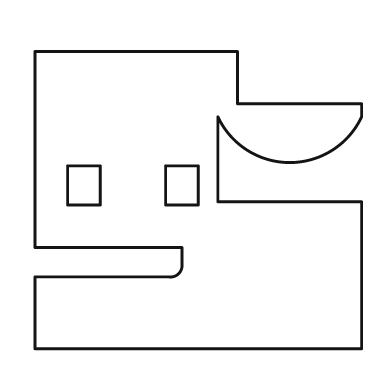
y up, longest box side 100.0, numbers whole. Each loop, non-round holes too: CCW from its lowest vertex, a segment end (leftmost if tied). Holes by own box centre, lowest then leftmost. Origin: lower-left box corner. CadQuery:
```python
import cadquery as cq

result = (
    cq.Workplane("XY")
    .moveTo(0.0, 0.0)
    .lineTo(100.0, 0.0)
    .lineTo(100.0, 45.0)
    .lineTo(56.0, 45.0)
    .lineTo(56.0, 71.0)
    .threePointArc((78.0, 57.0), (100.0, 71.0))
    .lineTo(100.0, 75.0)
    .lineTo(62.0, 75.0)
    .lineTo(62.0, 91.0)
    .lineTo(0.0, 91.0)
    .lineTo(0.0, 31.0)
    .lineTo(45.0, 31.0)
    .lineTo(45.0, 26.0)
    .threePointArc((44.0, 23.0), (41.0, 22.0))
    .lineTo(0.0, 22.0)
    .close()
    .moveTo(10.0, 44.0)
    .lineTo(20.0, 44.0)
    .lineTo(20.0, 56.0)
    .lineTo(10.0, 56.0)
    .close()
    .moveTo(40.0, 44.0)
    .lineTo(50.0, 44.0)
    .lineTo(50.0, 56.0)
    .lineTo(40.0, 56.0)
    .close()
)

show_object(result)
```